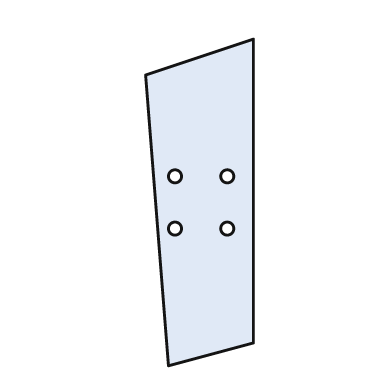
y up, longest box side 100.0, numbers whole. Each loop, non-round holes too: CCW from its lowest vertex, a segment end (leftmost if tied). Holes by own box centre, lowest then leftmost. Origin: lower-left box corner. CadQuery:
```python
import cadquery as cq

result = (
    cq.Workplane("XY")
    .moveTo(7.0, 0.0)
    .lineTo(33.0, 7.0)
    .lineTo(33.0, 100.0)
    .lineTo(0.0, 89.0)
    .close()
    .moveTo(9.0, 42.0)
    .circle(2.0)
    .moveTo(25.0, 42.0)
    .circle(2.0)
    .moveTo(9.0, 58.0)
    .circle(2.0)
    .moveTo(25.0, 58.0)
    .circle(2.0)
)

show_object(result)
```